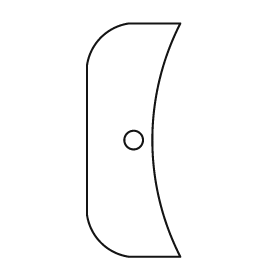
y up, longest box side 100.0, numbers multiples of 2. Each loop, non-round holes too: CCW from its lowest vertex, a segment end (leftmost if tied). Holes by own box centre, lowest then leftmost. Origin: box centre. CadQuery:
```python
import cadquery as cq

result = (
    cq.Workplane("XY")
    .moveTo(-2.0, -50.0)
    .lineTo(20.0, -50.0)
    .threePointArc((8.0, 0.0), (20.0, 50.0))
    .lineTo(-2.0, 50.0)
    .threePointArc((-14.0, 44.0), (-20.0, 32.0))
    .lineTo(-20.0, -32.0)
    .threePointArc((-14.0, -44.0), (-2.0, -50.0))
    .close()
    .moveTo(0.0, 0.0)
    .circle(4.0)
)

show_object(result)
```